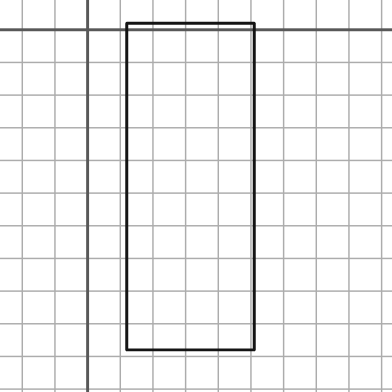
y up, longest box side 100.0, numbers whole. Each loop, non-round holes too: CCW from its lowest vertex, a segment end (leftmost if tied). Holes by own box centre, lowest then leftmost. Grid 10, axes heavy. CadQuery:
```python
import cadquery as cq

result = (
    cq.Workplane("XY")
    .moveTo(12.0, -98.0)
    .lineTo(51.0, -98.0)
    .lineTo(51.0, 2.0)
    .lineTo(12.0, 2.0)
    .close()
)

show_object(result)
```